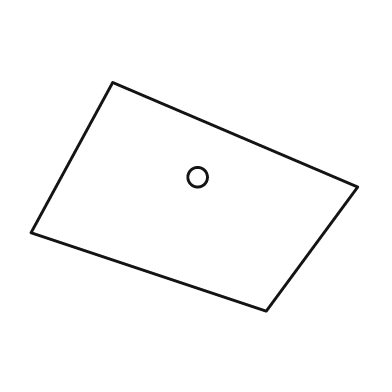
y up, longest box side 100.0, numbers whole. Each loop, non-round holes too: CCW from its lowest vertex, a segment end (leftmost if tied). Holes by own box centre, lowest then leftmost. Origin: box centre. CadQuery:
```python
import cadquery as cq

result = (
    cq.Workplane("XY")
    .moveTo(22.0, -35.0)
    .lineTo(50.0, 3.0)
    .lineTo(-25.0, 35.0)
    .lineTo(-50.0, -11.0)
    .close()
    .moveTo(1.0, 6.0)
    .circle(3.0)
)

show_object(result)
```